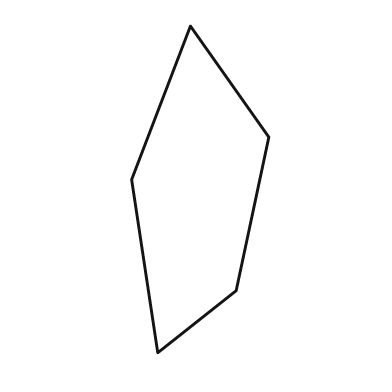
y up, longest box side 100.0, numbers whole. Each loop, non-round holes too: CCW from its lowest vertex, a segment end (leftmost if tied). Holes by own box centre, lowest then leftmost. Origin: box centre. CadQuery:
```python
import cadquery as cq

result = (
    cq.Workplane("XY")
    .moveTo(-13.0, -50.0)
    .lineTo(11.0, -31.0)
    .lineTo(21.0, 16.0)
    .lineTo(-3.0, 50.0)
    .lineTo(-21.0, 3.0)
    .close()
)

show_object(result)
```